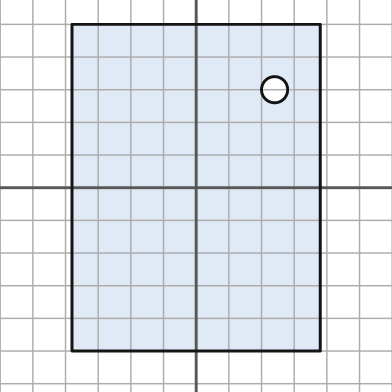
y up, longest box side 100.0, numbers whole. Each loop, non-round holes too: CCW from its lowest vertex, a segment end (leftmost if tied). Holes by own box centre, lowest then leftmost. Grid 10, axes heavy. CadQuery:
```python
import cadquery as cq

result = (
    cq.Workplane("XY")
    .moveTo(-38.0, -50.0)
    .lineTo(38.0, -50.0)
    .lineTo(38.0, 50.0)
    .lineTo(-38.0, 50.0)
    .close()
    .moveTo(24.0, 30.0)
    .circle(4.0)
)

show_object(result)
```